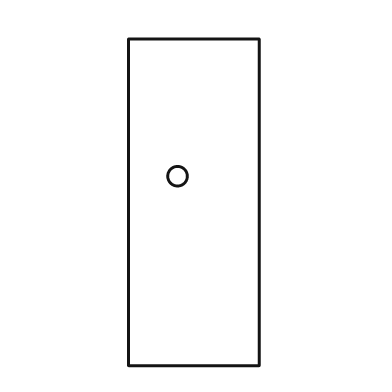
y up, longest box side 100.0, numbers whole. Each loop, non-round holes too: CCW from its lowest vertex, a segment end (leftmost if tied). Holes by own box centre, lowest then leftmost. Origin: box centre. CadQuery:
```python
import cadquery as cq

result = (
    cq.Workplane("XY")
    .moveTo(-20.0, -50.0)
    .lineTo(20.0, -50.0)
    .lineTo(20.0, 50.0)
    .lineTo(-20.0, 50.0)
    .close()
    .moveTo(-5.0, 8.0)
    .circle(3.0)
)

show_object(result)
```